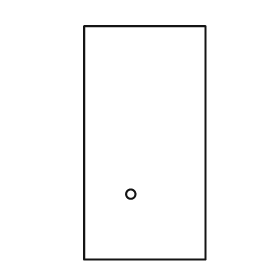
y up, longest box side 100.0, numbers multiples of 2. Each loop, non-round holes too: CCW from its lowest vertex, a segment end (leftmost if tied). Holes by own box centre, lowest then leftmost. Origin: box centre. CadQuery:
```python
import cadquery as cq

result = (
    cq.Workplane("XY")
    .moveTo(-26.0, -50.0)
    .lineTo(26.0, -50.0)
    .lineTo(26.0, 50.0)
    .lineTo(-26.0, 50.0)
    .close()
    .moveTo(-6.0, -22.0)
    .circle(2.0)
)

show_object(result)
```